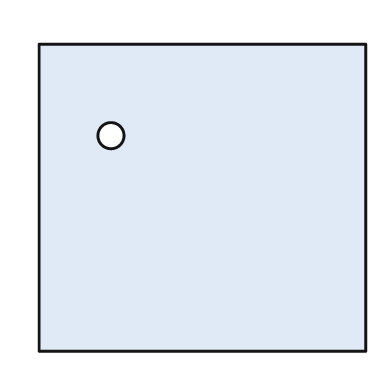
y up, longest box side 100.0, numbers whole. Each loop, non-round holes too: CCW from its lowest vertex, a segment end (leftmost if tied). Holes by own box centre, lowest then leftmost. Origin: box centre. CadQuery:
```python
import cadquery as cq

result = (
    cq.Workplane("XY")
    .moveTo(-50.0, -47.0)
    .lineTo(50.0, -47.0)
    .lineTo(50.0, 47.0)
    .lineTo(-50.0, 47.0)
    .close()
    .moveTo(-28.0, 19.0)
    .circle(4.0)
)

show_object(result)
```